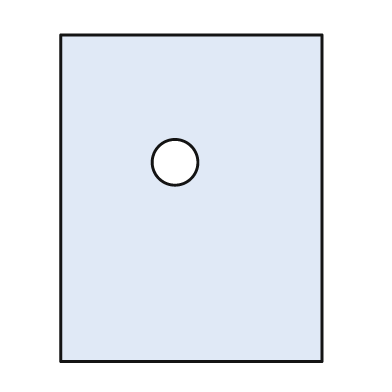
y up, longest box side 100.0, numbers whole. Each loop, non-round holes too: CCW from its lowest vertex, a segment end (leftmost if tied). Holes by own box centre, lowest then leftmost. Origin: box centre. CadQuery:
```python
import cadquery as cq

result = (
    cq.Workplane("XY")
    .moveTo(-40.0, -50.0)
    .lineTo(40.0, -50.0)
    .lineTo(40.0, 50.0)
    .lineTo(-40.0, 50.0)
    .close()
    .moveTo(-5.0, 11.0)
    .circle(7.0)
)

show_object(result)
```